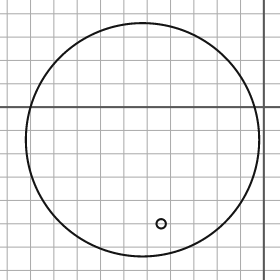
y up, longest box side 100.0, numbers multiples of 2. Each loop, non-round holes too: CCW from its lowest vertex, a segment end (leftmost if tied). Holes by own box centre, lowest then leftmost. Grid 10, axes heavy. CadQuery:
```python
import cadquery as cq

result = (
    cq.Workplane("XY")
    .moveTo(-52.0, -14.0)
    .circle(50.0)
    .moveTo(-44.0, -50.0)
    .circle(2.0)
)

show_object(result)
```